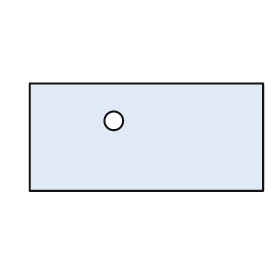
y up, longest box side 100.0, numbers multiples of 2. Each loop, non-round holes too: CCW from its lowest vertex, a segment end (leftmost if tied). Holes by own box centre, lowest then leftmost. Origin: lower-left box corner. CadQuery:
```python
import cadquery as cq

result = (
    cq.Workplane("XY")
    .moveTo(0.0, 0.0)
    .lineTo(100.0, 0.0)
    .lineTo(100.0, 46.0)
    .lineTo(0.0, 46.0)
    .close()
    .moveTo(36.0, 30.0)
    .circle(4.0)
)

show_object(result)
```